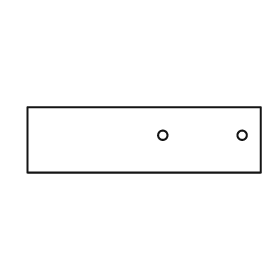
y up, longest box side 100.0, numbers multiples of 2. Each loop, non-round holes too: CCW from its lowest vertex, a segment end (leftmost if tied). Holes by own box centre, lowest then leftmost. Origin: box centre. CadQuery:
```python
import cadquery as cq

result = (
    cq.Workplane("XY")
    .moveTo(-50.0, -14.0)
    .lineTo(50.0, -14.0)
    .lineTo(50.0, 14.0)
    .lineTo(-50.0, 14.0)
    .close()
    .moveTo(8.0, 2.0)
    .circle(2.0)
    .moveTo(42.0, 2.0)
    .circle(2.0)
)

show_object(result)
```